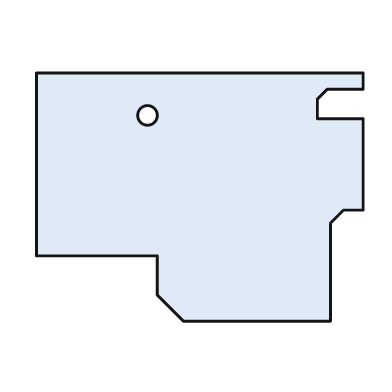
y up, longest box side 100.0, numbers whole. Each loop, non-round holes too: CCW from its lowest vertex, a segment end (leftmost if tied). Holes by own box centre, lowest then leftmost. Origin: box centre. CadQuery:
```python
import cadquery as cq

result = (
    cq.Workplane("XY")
    .moveTo(-5.0, -38.0)
    .lineTo(40.0, -38.0)
    .lineTo(40.0, -8.0)
    .lineTo(44.0, -4.0)
    .lineTo(50.0, -4.0)
    .lineTo(50.0, 24.0)
    .lineTo(36.0, 24.0)
    .lineTo(36.0, 30.0)
    .lineTo(39.0, 33.0)
    .lineTo(50.0, 33.0)
    .lineTo(50.0, 38.0)
    .lineTo(-50.0, 38.0)
    .lineTo(-50.0, -18.0)
    .lineTo(-13.0, -18.0)
    .lineTo(-13.0, -30.0)
    .close()
    .moveTo(-16.0, 25.0)
    .circle(3.0)
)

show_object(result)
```